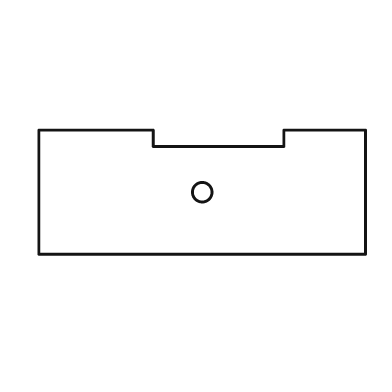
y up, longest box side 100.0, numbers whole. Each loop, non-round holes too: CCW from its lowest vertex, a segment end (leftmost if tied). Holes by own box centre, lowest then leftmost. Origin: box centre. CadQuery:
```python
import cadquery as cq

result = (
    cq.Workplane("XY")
    .moveTo(-50.0, -19.0)
    .lineTo(50.0, -19.0)
    .lineTo(50.0, 19.0)
    .lineTo(25.0, 19.0)
    .lineTo(25.0, 14.0)
    .lineTo(-15.0, 14.0)
    .lineTo(-15.0, 19.0)
    .lineTo(-50.0, 19.0)
    .close()
    .moveTo(0.0, 0.0)
    .circle(3.0)
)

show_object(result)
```